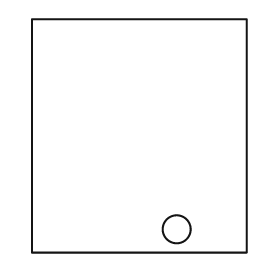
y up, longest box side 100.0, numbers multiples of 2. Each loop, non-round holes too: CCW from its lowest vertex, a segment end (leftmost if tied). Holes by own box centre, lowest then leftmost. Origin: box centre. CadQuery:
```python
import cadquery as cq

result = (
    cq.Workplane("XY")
    .moveTo(-46.0, -50.0)
    .lineTo(46.0, -50.0)
    .lineTo(46.0, 50.0)
    .lineTo(-46.0, 50.0)
    .close()
    .moveTo(16.0, -40.0)
    .circle(6.0)
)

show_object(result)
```